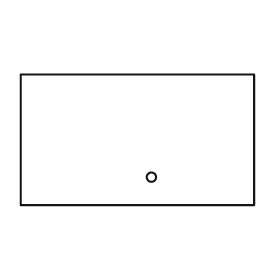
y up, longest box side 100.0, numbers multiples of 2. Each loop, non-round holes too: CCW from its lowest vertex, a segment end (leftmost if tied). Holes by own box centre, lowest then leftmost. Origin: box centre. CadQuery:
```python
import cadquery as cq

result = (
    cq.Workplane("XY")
    .moveTo(-50.0, -28.0)
    .lineTo(50.0, -28.0)
    .lineTo(50.0, 28.0)
    .lineTo(-50.0, 28.0)
    .close()
    .moveTo(6.0, -16.0)
    .circle(2.0)
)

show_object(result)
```